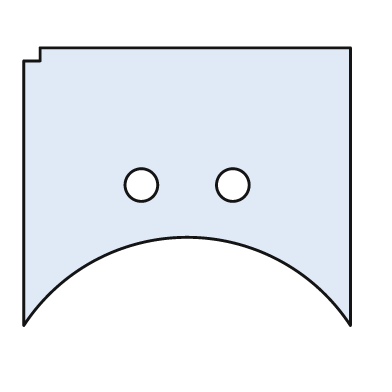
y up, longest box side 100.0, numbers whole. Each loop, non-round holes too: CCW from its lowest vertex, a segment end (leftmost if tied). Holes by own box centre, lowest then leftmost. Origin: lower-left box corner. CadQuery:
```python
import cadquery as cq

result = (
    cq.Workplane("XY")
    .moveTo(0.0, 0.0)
    .threePointArc((50.0, 27.0), (100.0, 0.0))
    .lineTo(100.0, 85.0)
    .lineTo(5.0, 85.0)
    .lineTo(5.0, 81.0)
    .lineTo(0.0, 81.0)
    .close()
    .moveTo(36.0, 43.0)
    .circle(5.0)
    .moveTo(64.0, 43.0)
    .circle(5.0)
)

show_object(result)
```